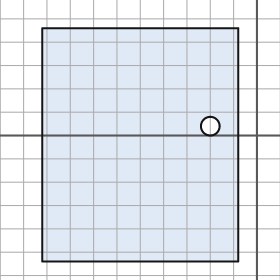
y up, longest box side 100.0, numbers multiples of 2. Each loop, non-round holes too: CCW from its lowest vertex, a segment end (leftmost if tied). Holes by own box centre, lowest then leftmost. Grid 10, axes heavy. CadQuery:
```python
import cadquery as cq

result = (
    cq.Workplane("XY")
    .moveTo(-92.0, -54.0)
    .lineTo(-8.0, -54.0)
    .lineTo(-8.0, 46.0)
    .lineTo(-92.0, 46.0)
    .close()
    .moveTo(-20.0, 4.0)
    .circle(4.0)
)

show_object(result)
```